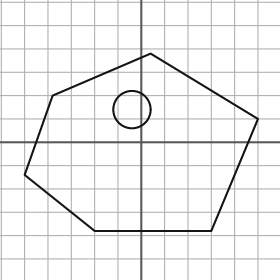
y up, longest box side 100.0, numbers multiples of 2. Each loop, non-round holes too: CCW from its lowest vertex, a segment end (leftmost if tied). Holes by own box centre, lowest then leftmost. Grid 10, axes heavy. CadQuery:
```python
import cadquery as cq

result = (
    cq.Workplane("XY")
    .moveTo(-20.0, -38.0)
    .lineTo(30.0, -38.0)
    .lineTo(50.0, 10.0)
    .lineTo(4.0, 38.0)
    .lineTo(-38.0, 20.0)
    .lineTo(-50.0, -14.0)
    .close()
    .moveTo(-4.0, 14.0)
    .circle(8.0)
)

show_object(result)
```